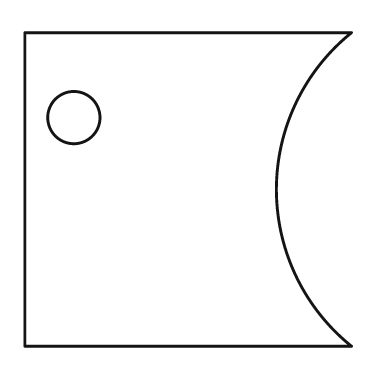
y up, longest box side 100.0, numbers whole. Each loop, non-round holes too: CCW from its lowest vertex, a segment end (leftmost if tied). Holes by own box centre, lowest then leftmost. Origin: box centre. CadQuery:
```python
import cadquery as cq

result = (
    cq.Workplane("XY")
    .moveTo(-50.0, -48.0)
    .lineTo(50.0, -48.0)
    .threePointArc((27.0, 0.0), (50.0, 48.0))
    .lineTo(-50.0, 48.0)
    .close()
    .moveTo(-35.0, 22.0)
    .circle(8.0)
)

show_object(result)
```